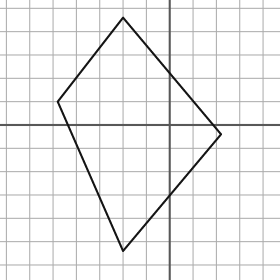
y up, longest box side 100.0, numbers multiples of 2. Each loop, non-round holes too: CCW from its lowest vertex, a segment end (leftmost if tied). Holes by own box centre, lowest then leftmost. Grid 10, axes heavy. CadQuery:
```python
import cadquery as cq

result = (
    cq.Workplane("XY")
    .moveTo(-20.0, -54.0)
    .lineTo(22.0, -4.0)
    .lineTo(-20.0, 46.0)
    .lineTo(-48.0, 10.0)
    .close()
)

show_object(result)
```